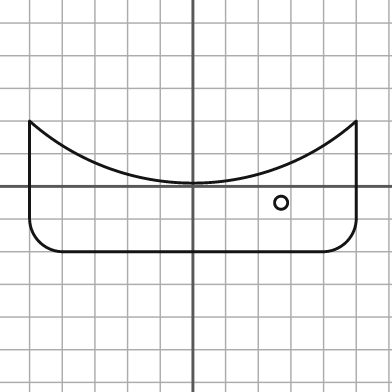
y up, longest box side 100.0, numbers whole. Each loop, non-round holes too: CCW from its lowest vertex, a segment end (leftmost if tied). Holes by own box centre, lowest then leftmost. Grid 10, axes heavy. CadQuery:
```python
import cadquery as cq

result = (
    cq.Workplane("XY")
    .moveTo(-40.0, -20.0)
    .lineTo(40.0, -20.0)
    .threePointArc((47.0, -17.0), (50.0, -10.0))
    .lineTo(50.0, 20.0)
    .threePointArc((0.0, 1.0), (-50.0, 20.0))
    .lineTo(-50.0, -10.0)
    .threePointArc((-47.0, -17.0), (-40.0, -20.0))
    .close()
    .moveTo(27.0, -5.0)
    .circle(2.0)
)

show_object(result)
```